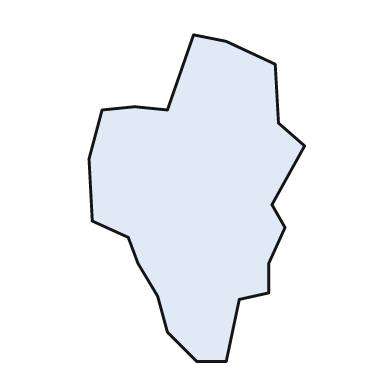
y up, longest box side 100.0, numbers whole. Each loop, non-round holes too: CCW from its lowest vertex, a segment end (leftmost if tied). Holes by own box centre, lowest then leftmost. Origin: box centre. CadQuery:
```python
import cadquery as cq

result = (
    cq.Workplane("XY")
    .moveTo(0.0, -50.0)
    .lineTo(9.0, -50.0)
    .lineTo(13.0, -31.0)
    .lineTo(22.0, -29.0)
    .lineTo(22.0, -20.0)
    .lineTo(27.0, -9.0)
    .lineTo(23.0, -2.0)
    .lineTo(33.0, 16.0)
    .lineTo(25.0, 23.0)
    .lineTo(24.0, 41.0)
    .lineTo(9.0, 48.0)
    .lineTo(-1.0, 50.0)
    .lineTo(-9.0, 27.0)
    .lineTo(-19.0, 28.0)
    .lineTo(-29.0, 27.0)
    .lineTo(-33.0, 12.0)
    .lineTo(-32.0, -7.0)
    .lineTo(-21.0, -12.0)
    .lineTo(-18.0, -20.0)
    .lineTo(-12.0, -30.0)
    .lineTo(-9.0, -41.0)
    .close()
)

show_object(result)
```